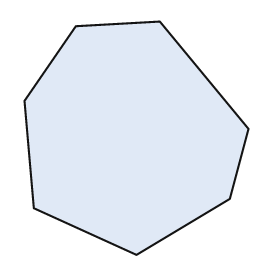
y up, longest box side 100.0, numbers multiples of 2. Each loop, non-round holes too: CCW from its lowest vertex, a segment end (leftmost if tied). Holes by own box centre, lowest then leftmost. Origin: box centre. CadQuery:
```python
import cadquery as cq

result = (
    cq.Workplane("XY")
    .moveTo(0.0, -50.0)
    .lineTo(40.0, -26.0)
    .lineTo(48.0, 4.0)
    .lineTo(10.0, 50.0)
    .lineTo(-26.0, 48.0)
    .lineTo(-48.0, 16.0)
    .lineTo(-44.0, -30.0)
    .close()
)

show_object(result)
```